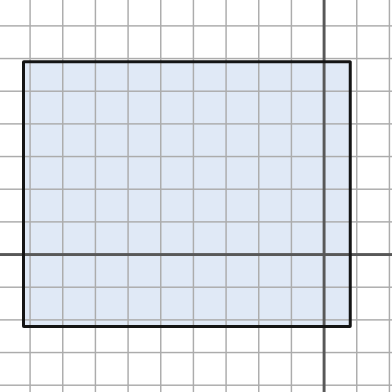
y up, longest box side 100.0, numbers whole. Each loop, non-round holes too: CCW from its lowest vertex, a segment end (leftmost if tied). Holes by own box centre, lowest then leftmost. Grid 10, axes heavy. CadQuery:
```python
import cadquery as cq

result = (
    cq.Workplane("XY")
    .moveTo(-92.0, -22.0)
    .lineTo(8.0, -22.0)
    .lineTo(8.0, 59.0)
    .lineTo(-92.0, 59.0)
    .close()
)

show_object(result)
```